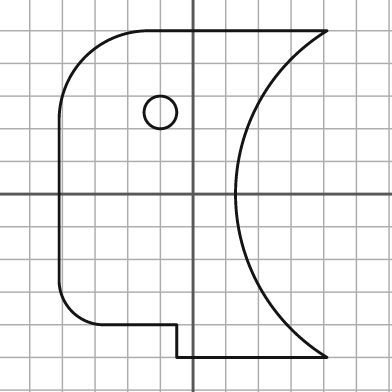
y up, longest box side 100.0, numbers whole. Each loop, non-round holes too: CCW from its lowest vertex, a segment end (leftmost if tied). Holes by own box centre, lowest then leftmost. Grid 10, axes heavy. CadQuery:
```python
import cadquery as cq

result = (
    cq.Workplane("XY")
    .moveTo(-5.0, -50.0)
    .lineTo(41.0, -50.0)
    .threePointArc((13.0, 0.0), (41.0, 50.0))
    .lineTo(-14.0, 50.0)
    .threePointArc((-33.0, 42.0), (-41.0, 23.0))
    .lineTo(-41.0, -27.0)
    .threePointArc((-37.0, -36.0), (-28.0, -40.0))
    .lineTo(-5.0, -40.0)
    .close()
    .moveTo(-10.0, 25.0)
    .circle(5.0)
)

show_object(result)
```